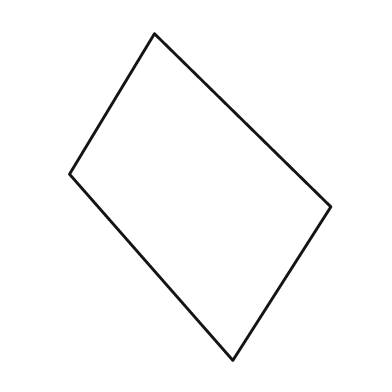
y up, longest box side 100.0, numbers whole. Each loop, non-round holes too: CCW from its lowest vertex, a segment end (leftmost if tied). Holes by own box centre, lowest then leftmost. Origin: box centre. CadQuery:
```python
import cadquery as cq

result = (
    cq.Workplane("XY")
    .moveTo(10.0, -50.0)
    .lineTo(40.0, -3.0)
    .lineTo(-14.0, 50.0)
    .lineTo(-40.0, 7.0)
    .close()
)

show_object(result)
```